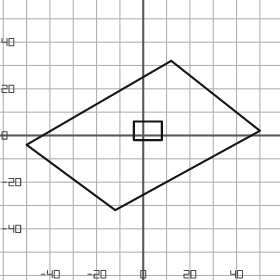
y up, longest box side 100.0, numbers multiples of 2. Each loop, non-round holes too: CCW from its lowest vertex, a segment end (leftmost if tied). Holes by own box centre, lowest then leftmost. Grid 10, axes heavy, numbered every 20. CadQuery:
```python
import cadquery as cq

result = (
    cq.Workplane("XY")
    .moveTo(-12.0, -32.0)
    .lineTo(50.0, 2.0)
    .lineTo(12.0, 32.0)
    .lineTo(-50.0, -4.0)
    .close()
    .moveTo(-4.0, -2.0)
    .lineTo(8.0, -2.0)
    .lineTo(8.0, 6.0)
    .lineTo(-4.0, 6.0)
    .close()
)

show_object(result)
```